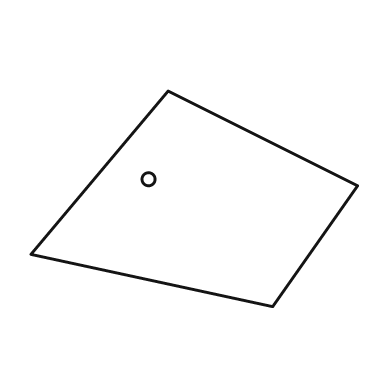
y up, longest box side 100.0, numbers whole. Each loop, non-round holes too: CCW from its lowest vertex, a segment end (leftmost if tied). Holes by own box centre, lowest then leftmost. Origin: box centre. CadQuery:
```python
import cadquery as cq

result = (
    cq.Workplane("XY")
    .moveTo(24.0, -33.0)
    .lineTo(50.0, 4.0)
    .lineTo(-8.0, 33.0)
    .lineTo(-50.0, -17.0)
    .close()
    .moveTo(-14.0, 6.0)
    .circle(2.0)
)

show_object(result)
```